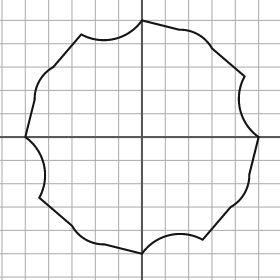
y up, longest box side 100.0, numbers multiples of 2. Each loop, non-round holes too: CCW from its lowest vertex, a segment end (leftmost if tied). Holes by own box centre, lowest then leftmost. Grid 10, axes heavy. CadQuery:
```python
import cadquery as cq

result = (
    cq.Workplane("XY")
    .moveTo(0.0, -50.0)
    .threePointArc((12.0, -42.0), (26.0, -44.0))
    .lineTo(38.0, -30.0)
    .threePointArc((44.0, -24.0), (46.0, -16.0))
    .lineTo(50.0, 0.0)
    .threePointArc((42.0, 12.0), (44.0, 26.0))
    .lineTo(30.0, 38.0)
    .threePointArc((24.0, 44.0), (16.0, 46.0))
    .lineTo(0.0, 50.0)
    .threePointArc((-12.0, 42.0), (-26.0, 44.0))
    .lineTo(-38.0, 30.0)
    .threePointArc((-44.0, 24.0), (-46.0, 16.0))
    .lineTo(-50.0, 0.0)
    .threePointArc((-42.0, -12.0), (-44.0, -26.0))
    .lineTo(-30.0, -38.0)
    .threePointArc((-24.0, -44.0), (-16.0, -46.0))
    .close()
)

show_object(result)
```